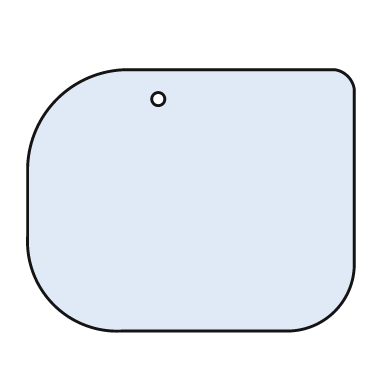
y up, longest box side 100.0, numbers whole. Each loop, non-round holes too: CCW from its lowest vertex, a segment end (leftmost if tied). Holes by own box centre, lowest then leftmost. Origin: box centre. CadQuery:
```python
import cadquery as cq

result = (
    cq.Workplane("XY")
    .moveTo(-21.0, -40.0)
    .lineTo(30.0, -40.0)
    .threePointArc((44.0, -34.0), (50.0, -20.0))
    .lineTo(50.0, 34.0)
    .threePointArc((48.0, 38.0), (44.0, 40.0))
    .lineTo(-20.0, 40.0)
    .threePointArc((-41.0, 31.0), (-50.0, 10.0))
    .lineTo(-50.0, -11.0)
    .threePointArc((-42.0, -32.0), (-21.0, -40.0))
    .close()
    .moveTo(-10.0, 31.0)
    .circle(2.0)
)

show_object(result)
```